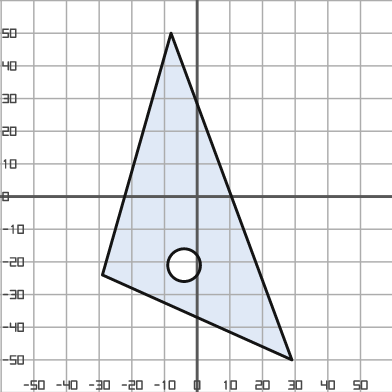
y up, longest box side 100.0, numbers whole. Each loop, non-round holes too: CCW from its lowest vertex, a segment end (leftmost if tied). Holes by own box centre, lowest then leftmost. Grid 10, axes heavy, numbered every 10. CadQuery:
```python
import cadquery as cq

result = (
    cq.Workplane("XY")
    .moveTo(29.0, -50.0)
    .lineTo(-8.0, 50.0)
    .lineTo(-29.0, -24.0)
    .close()
    .moveTo(-4.0, -21.0)
    .circle(5.0)
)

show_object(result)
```